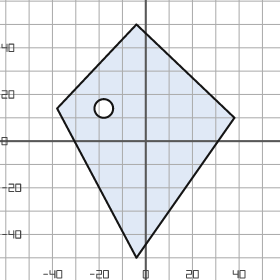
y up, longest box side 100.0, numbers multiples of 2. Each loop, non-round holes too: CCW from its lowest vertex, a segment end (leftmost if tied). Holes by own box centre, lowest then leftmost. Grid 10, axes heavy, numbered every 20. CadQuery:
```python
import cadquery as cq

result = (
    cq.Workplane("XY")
    .moveTo(-4.0, -50.0)
    .lineTo(38.0, 10.0)
    .lineTo(-4.0, 50.0)
    .lineTo(-38.0, 14.0)
    .close()
    .moveTo(-18.0, 14.0)
    .circle(4.0)
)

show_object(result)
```